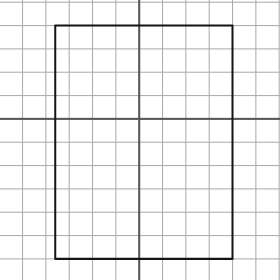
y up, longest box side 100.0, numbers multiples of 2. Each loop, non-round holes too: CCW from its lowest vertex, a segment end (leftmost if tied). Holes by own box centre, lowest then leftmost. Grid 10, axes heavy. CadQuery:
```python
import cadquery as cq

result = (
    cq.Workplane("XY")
    .moveTo(-36.0, -60.0)
    .lineTo(40.0, -60.0)
    .lineTo(40.0, 40.0)
    .lineTo(-36.0, 40.0)
    .close()
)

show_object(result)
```